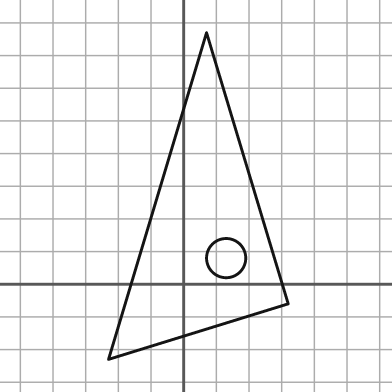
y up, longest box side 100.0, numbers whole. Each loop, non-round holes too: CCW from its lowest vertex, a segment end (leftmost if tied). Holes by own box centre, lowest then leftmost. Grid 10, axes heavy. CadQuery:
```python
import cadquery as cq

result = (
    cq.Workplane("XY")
    .moveTo(-23.0, -23.0)
    .lineTo(32.0, -6.0)
    .lineTo(7.0, 77.0)
    .close()
    .moveTo(13.0, 8.0)
    .circle(6.0)
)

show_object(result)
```